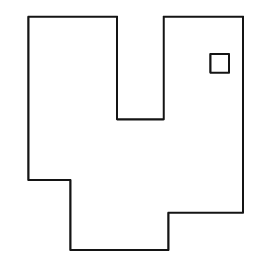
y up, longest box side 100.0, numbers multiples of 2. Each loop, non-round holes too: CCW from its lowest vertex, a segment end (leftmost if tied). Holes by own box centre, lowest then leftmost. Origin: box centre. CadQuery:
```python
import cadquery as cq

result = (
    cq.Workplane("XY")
    .moveTo(-28.0, -50.0)
    .lineTo(14.0, -50.0)
    .lineTo(14.0, -34.0)
    .lineTo(46.0, -34.0)
    .lineTo(46.0, 50.0)
    .lineTo(12.0, 50.0)
    .lineTo(12.0, 6.0)
    .lineTo(-8.0, 6.0)
    .lineTo(-8.0, 50.0)
    .lineTo(-46.0, 50.0)
    .lineTo(-46.0, -20.0)
    .lineTo(-28.0, -20.0)
    .close()
    .moveTo(32.0, 26.0)
    .lineTo(40.0, 26.0)
    .lineTo(40.0, 34.0)
    .lineTo(32.0, 34.0)
    .close()
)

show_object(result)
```